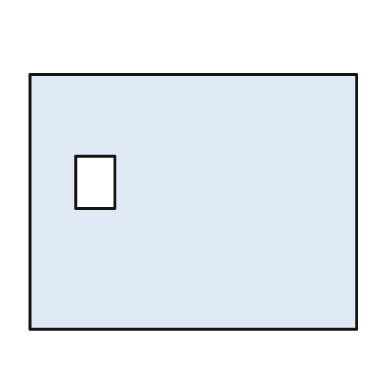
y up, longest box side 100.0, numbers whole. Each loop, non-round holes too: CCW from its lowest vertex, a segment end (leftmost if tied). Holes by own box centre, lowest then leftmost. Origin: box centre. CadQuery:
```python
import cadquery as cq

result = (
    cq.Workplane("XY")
    .moveTo(-50.0, -39.0)
    .lineTo(50.0, -39.0)
    .lineTo(50.0, 39.0)
    .lineTo(-50.0, 39.0)
    .close()
    .moveTo(-36.0, -2.0)
    .lineTo(-24.0, -2.0)
    .lineTo(-24.0, 14.0)
    .lineTo(-36.0, 14.0)
    .close()
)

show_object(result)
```